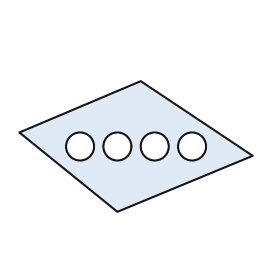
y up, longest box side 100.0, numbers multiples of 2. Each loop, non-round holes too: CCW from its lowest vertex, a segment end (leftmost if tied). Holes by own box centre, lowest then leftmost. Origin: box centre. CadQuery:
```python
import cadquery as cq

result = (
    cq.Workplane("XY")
    .moveTo(-8.0, -28.0)
    .lineTo(50.0, -4.0)
    .lineTo(2.0, 28.0)
    .lineTo(-50.0, 6.0)
    .close()
    .moveTo(-24.0, 0.0)
    .circle(6.0)
    .moveTo(-8.0, 0.0)
    .circle(6.0)
    .moveTo(8.0, 0.0)
    .circle(6.0)
    .moveTo(24.0, 0.0)
    .circle(6.0)
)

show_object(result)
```